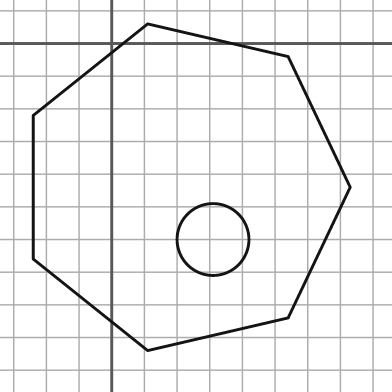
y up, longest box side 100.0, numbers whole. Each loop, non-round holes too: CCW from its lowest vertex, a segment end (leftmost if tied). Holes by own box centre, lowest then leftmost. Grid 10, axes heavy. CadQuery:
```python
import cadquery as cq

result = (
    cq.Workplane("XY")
    .moveTo(11.0, -94.0)
    .lineTo(54.0, -84.0)
    .lineTo(73.0, -44.0)
    .lineTo(54.0, -4.0)
    .lineTo(11.0, 6.0)
    .lineTo(-24.0, -22.0)
    .lineTo(-24.0, -66.0)
    .close()
    .moveTo(31.0, -60.0)
    .circle(11.0)
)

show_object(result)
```